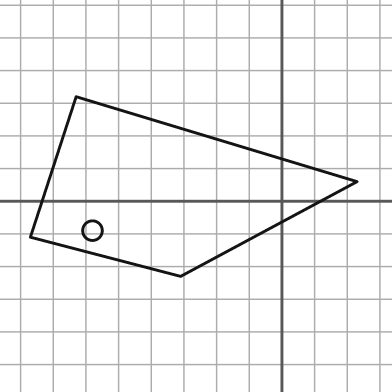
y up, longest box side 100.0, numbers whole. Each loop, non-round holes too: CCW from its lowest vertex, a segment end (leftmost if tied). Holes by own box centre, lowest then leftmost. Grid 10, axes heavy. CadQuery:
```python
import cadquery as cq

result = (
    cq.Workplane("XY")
    .moveTo(-31.0, -23.0)
    .lineTo(23.0, 6.0)
    .lineTo(-63.0, 32.0)
    .lineTo(-77.0, -11.0)
    .close()
    .moveTo(-58.0, -9.0)
    .circle(3.0)
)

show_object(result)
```